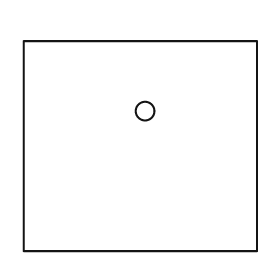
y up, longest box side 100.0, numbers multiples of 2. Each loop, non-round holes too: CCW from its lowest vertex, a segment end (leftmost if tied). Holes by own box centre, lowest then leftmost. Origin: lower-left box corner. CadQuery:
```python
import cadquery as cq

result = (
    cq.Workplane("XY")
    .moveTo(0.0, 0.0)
    .lineTo(100.0, 0.0)
    .lineTo(100.0, 90.0)
    .lineTo(0.0, 90.0)
    .close()
    .moveTo(52.0, 60.0)
    .circle(4.0)
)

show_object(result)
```